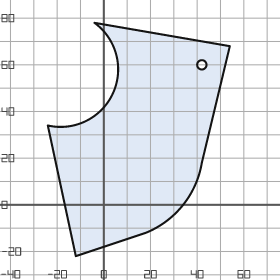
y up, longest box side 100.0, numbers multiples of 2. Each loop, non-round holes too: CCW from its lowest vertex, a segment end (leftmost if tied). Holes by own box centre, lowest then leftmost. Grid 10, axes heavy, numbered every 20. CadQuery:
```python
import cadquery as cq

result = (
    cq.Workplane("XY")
    .moveTo(-12.0, -22.0)
    .lineTo(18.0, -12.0)
    .threePointArc((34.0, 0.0), (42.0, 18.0))
    .lineTo(54.0, 68.0)
    .lineTo(-4.0, 78.0)
    .threePointArc((4.0, 48.0), (-24.0, 34.0))
    .close()
    .moveTo(42.0, 60.0)
    .circle(2.0)
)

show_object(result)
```